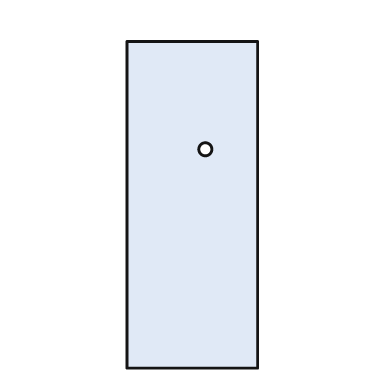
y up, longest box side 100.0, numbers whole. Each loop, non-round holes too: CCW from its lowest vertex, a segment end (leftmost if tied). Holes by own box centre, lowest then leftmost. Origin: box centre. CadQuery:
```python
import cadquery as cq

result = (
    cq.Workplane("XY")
    .moveTo(-20.0, -50.0)
    .lineTo(20.0, -50.0)
    .lineTo(20.0, 50.0)
    .lineTo(-20.0, 50.0)
    .close()
    .moveTo(4.0, 17.0)
    .circle(2.0)
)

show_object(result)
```